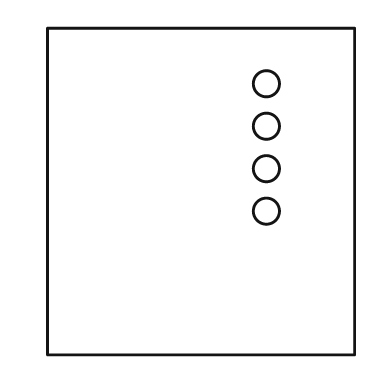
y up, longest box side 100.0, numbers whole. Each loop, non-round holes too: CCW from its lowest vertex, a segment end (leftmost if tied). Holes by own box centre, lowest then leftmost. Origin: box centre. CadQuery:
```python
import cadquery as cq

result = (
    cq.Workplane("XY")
    .moveTo(-47.0, -50.0)
    .lineTo(47.0, -50.0)
    .lineTo(47.0, 50.0)
    .lineTo(-47.0, 50.0)
    .close()
    .moveTo(20.0, -6.0)
    .circle(4.0)
    .moveTo(20.0, 7.0)
    .circle(4.0)
    .moveTo(20.0, 20.0)
    .circle(4.0)
    .moveTo(20.0, 33.0)
    .circle(4.0)
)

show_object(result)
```